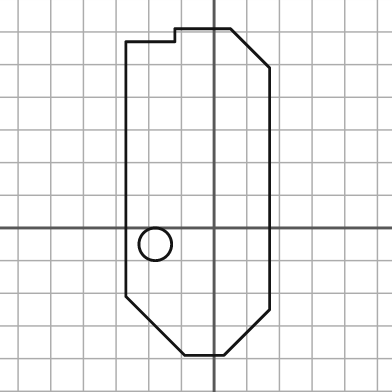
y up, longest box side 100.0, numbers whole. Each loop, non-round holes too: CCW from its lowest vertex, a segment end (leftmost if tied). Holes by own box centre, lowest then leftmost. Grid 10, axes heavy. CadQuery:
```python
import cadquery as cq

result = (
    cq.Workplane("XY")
    .moveTo(-9.0, -39.0)
    .lineTo(3.0, -39.0)
    .lineTo(17.0, -25.0)
    .lineTo(17.0, 49.0)
    .lineTo(5.0, 61.0)
    .lineTo(-12.0, 61.0)
    .lineTo(-12.0, 57.0)
    .lineTo(-27.0, 57.0)
    .lineTo(-27.0, -21.0)
    .close()
    .moveTo(-18.0, -5.0)
    .circle(5.0)
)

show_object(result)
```